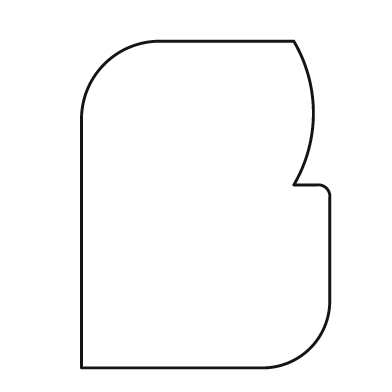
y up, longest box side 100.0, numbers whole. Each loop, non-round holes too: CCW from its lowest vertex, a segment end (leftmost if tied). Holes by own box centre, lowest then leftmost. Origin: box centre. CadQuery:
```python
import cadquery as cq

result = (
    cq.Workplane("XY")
    .moveTo(-38.0, -50.0)
    .lineTo(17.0, -50.0)
    .threePointArc((32.0, -44.0), (38.0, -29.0))
    .lineTo(38.0, 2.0)
    .threePointArc((37.0, 5.0), (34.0, 6.0))
    .lineTo(27.0, 6.0)
    .threePointArc((33.0, 28.0), (27.0, 50.0))
    .lineTo(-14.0, 50.0)
    .threePointArc((-31.0, 43.0), (-38.0, 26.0))
    .close()
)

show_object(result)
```